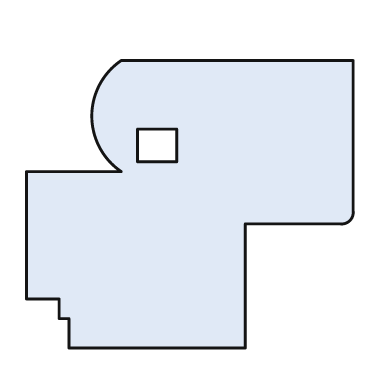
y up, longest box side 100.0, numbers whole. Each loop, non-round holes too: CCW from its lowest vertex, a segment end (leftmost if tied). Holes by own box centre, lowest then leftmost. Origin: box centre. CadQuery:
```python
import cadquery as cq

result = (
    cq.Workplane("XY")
    .moveTo(-37.0, -44.0)
    .lineTo(17.0, -44.0)
    .lineTo(17.0, -6.0)
    .lineTo(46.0, -6.0)
    .threePointArc((49.0, -5.0), (50.0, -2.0))
    .lineTo(50.0, 44.0)
    .lineTo(-21.0, 44.0)
    .threePointArc((-30.0, 27.0), (-21.0, 10.0))
    .lineTo(-50.0, 10.0)
    .lineTo(-50.0, -29.0)
    .lineTo(-40.0, -29.0)
    .lineTo(-40.0, -35.0)
    .lineTo(-37.0, -35.0)
    .close()
    .moveTo(-16.0, 13.0)
    .lineTo(-4.0, 13.0)
    .lineTo(-4.0, 23.0)
    .lineTo(-16.0, 23.0)
    .close()
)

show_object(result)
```